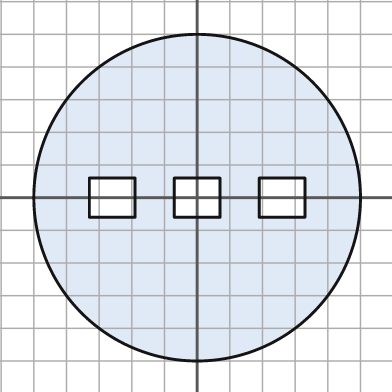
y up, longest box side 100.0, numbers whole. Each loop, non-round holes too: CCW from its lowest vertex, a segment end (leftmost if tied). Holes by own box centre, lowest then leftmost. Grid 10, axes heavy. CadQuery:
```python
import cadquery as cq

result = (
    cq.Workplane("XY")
    .moveTo(0.0, 0.0)
    .circle(50.0)
    .moveTo(-33.0, -6.0)
    .lineTo(-19.0, -6.0)
    .lineTo(-19.0, 6.0)
    .lineTo(-33.0, 6.0)
    .close()
    .moveTo(-7.0, -6.0)
    .lineTo(7.0, -6.0)
    .lineTo(7.0, 6.0)
    .lineTo(-7.0, 6.0)
    .close()
    .moveTo(19.0, -6.0)
    .lineTo(33.0, -6.0)
    .lineTo(33.0, 6.0)
    .lineTo(19.0, 6.0)
    .close()
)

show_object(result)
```